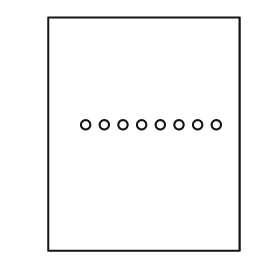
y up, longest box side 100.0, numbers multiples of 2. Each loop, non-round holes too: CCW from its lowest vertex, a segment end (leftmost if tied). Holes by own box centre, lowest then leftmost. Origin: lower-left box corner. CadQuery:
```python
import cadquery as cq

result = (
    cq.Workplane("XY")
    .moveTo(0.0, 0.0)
    .lineTo(82.0, 0.0)
    .lineTo(82.0, 100.0)
    .lineTo(0.0, 100.0)
    .close()
    .moveTo(16.0, 54.0)
    .circle(2.0)
    .moveTo(24.0, 54.0)
    .circle(2.0)
    .moveTo(32.0, 54.0)
    .circle(2.0)
    .moveTo(40.0, 54.0)
    .circle(2.0)
    .moveTo(48.0, 54.0)
    .circle(2.0)
    .moveTo(56.0, 54.0)
    .circle(2.0)
    .moveTo(64.0, 54.0)
    .circle(2.0)
    .moveTo(72.0, 54.0)
    .circle(2.0)
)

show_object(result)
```